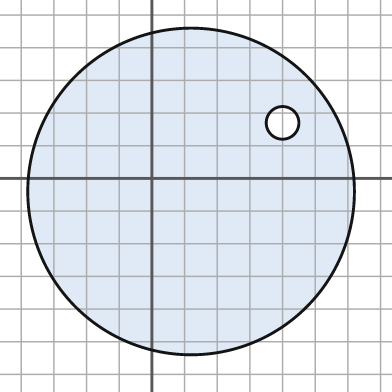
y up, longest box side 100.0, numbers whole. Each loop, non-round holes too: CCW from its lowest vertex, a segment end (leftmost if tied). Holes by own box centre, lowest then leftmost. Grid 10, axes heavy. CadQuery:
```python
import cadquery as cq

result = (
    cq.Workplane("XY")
    .moveTo(12.0, -4.0)
    .circle(50.0)
    .moveTo(40.0, 17.0)
    .circle(5.0)
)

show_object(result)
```